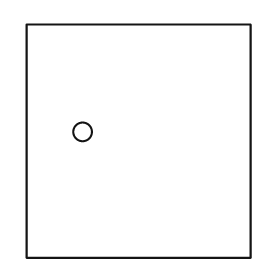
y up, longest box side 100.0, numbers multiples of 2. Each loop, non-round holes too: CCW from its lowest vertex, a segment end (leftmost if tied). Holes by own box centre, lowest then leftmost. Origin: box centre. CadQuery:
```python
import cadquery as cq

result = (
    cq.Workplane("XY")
    .moveTo(-48.0, -50.0)
    .lineTo(48.0, -50.0)
    .lineTo(48.0, 50.0)
    .lineTo(-48.0, 50.0)
    .close()
    .moveTo(-24.0, 4.0)
    .circle(4.0)
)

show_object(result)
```